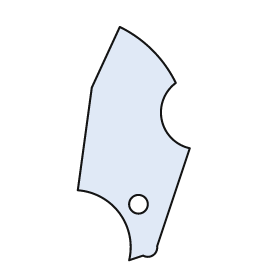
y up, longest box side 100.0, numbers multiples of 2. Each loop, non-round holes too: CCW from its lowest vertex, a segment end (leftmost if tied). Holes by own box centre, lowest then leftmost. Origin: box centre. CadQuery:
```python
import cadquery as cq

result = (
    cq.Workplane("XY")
    .moveTo(-2.0, -50.0)
    .lineTo(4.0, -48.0)
    .threePointArc((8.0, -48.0), (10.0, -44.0))
    .lineTo(24.0, -2.0)
    .threePointArc((12.0, 10.0), (18.0, 26.0))
    .threePointArc((8.0, 40.0), (-6.0, 50.0))
    .lineTo(-18.0, 24.0)
    .lineTo(-24.0, -20.0)
    .threePointArc((-6.0, -30.0), (-2.0, -50.0))
    .close()
    .moveTo(2.0, -26.0)
    .circle(4.0)
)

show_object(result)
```